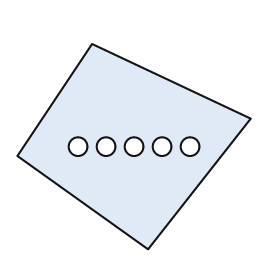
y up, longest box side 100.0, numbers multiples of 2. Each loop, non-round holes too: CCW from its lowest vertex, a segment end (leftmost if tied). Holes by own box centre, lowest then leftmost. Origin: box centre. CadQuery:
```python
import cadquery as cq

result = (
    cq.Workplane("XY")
    .moveTo(6.0, -44.0)
    .lineTo(50.0, 12.0)
    .lineTo(-18.0, 44.0)
    .lineTo(-50.0, -4.0)
    .close()
    .moveTo(-24.0, 0.0)
    .circle(4.0)
    .moveTo(-12.0, 0.0)
    .circle(4.0)
    .moveTo(0.0, 0.0)
    .circle(4.0)
    .moveTo(12.0, 0.0)
    .circle(4.0)
    .moveTo(24.0, 0.0)
    .circle(4.0)
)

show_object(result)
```